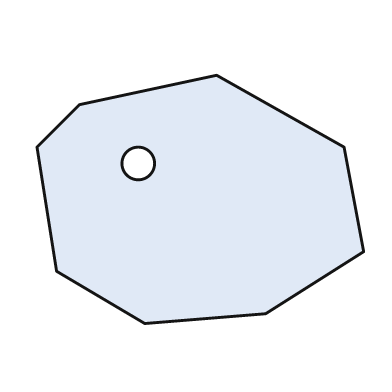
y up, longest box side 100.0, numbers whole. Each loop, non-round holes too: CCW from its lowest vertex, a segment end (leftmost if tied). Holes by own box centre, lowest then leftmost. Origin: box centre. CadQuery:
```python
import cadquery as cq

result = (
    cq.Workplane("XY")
    .moveTo(-17.0, -38.0)
    .lineTo(20.0, -35.0)
    .lineTo(50.0, -16.0)
    .lineTo(44.0, 16.0)
    .lineTo(5.0, 38.0)
    .lineTo(-37.0, 29.0)
    .lineTo(-50.0, 16.0)
    .lineTo(-44.0, -22.0)
    .close()
    .moveTo(-19.0, 11.0)
    .circle(5.0)
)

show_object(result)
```